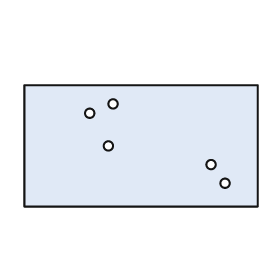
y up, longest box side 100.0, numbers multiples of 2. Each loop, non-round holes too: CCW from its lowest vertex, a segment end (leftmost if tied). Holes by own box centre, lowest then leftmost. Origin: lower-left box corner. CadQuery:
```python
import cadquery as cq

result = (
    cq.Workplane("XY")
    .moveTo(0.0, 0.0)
    .lineTo(100.0, 0.0)
    .lineTo(100.0, 52.0)
    .lineTo(0.0, 52.0)
    .close()
    .moveTo(86.0, 10.0)
    .circle(2.0)
    .moveTo(80.0, 18.0)
    .circle(2.0)
    .moveTo(36.0, 26.0)
    .circle(2.0)
    .moveTo(28.0, 40.0)
    .circle(2.0)
    .moveTo(38.0, 44.0)
    .circle(2.0)
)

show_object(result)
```